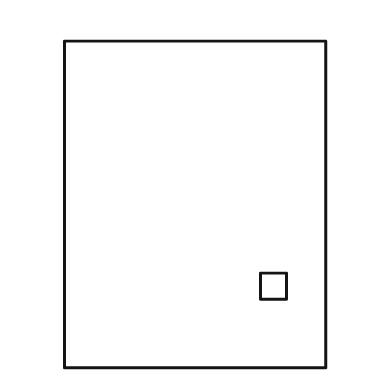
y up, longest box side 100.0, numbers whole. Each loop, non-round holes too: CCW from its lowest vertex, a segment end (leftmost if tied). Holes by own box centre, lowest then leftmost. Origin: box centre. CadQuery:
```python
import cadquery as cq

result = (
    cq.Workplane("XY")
    .moveTo(-40.0, -50.0)
    .lineTo(40.0, -50.0)
    .lineTo(40.0, 50.0)
    .lineTo(-40.0, 50.0)
    .close()
    .moveTo(20.0, -29.0)
    .lineTo(28.0, -29.0)
    .lineTo(28.0, -21.0)
    .lineTo(20.0, -21.0)
    .close()
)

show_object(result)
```